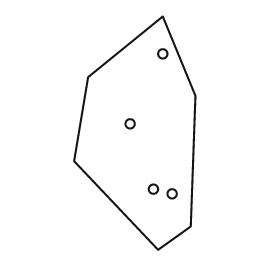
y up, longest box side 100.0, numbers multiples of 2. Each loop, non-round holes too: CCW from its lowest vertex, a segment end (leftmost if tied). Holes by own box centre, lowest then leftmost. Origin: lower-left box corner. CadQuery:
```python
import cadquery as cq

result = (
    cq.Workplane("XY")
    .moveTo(36.0, 0.0)
    .lineTo(50.0, 10.0)
    .lineTo(52.0, 66.0)
    .lineTo(38.0, 100.0)
    .lineTo(6.0, 74.0)
    .lineTo(0.0, 38.0)
    .close()
    .moveTo(42.0, 24.0)
    .circle(2.0)
    .moveTo(34.0, 26.0)
    .circle(2.0)
    .moveTo(24.0, 54.0)
    .circle(2.0)
    .moveTo(38.0, 84.0)
    .circle(2.0)
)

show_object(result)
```